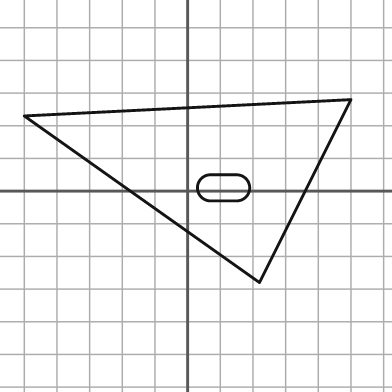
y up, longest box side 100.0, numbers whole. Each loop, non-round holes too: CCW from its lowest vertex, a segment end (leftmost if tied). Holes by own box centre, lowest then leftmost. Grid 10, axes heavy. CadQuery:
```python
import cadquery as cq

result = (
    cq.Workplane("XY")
    .moveTo(22.0, -28.0)
    .lineTo(50.0, 28.0)
    .lineTo(-50.0, 23.0)
    .close()
    .moveTo(7.0, -3.0)
    .lineTo(15.0, -3.0)
    .threePointArc((19.0, 1.0), (15.0, 5.0))
    .lineTo(7.0, 5.0)
    .threePointArc((3.0, 1.0), (7.0, -3.0))
    .close()
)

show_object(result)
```